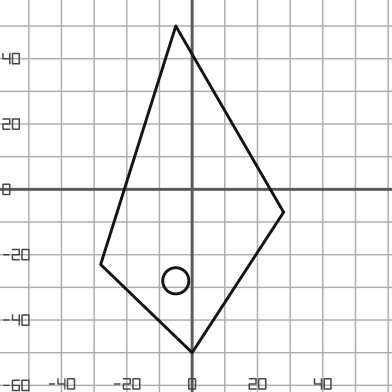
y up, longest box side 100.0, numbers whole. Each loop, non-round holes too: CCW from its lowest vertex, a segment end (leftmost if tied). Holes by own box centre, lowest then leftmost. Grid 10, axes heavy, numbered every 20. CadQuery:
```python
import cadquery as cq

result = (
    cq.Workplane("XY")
    .moveTo(0.0, -50.0)
    .lineTo(28.0, -7.0)
    .lineTo(-5.0, 50.0)
    .lineTo(-28.0, -23.0)
    .close()
    .moveTo(-5.0, -28.0)
    .circle(4.0)
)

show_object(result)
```